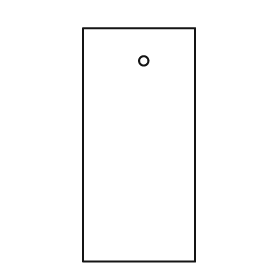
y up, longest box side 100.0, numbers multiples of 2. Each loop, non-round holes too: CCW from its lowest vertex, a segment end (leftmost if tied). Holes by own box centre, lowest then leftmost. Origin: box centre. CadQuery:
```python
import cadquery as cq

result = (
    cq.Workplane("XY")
    .moveTo(-24.0, -50.0)
    .lineTo(24.0, -50.0)
    .lineTo(24.0, 50.0)
    .lineTo(-24.0, 50.0)
    .close()
    .moveTo(2.0, 36.0)
    .circle(2.0)
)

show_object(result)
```